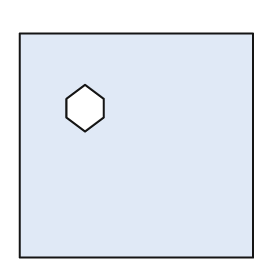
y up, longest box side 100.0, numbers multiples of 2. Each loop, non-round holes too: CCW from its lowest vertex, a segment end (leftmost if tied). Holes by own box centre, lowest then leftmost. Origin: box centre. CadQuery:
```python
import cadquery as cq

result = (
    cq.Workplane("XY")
    .moveTo(-50.0, -48.0)
    .lineTo(50.0, -48.0)
    .lineTo(50.0, 48.0)
    .lineTo(-50.0, 48.0)
    .close()
    .moveTo(-22.0, 6.0)
    .lineTo(-14.0, 12.0)
    .lineTo(-14.0, 20.0)
    .lineTo(-22.0, 26.0)
    .lineTo(-30.0, 20.0)
    .lineTo(-30.0, 12.0)
    .close()
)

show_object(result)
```